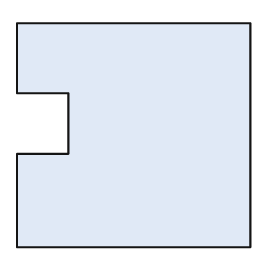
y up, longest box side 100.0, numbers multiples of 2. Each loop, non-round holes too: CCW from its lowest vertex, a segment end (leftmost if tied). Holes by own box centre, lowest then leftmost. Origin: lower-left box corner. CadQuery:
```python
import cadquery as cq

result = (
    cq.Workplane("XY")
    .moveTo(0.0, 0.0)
    .lineTo(100.0, 0.0)
    .lineTo(100.0, 96.0)
    .lineTo(0.0, 96.0)
    .lineTo(0.0, 66.0)
    .lineTo(22.0, 66.0)
    .lineTo(22.0, 40.0)
    .lineTo(0.0, 40.0)
    .close()
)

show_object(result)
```